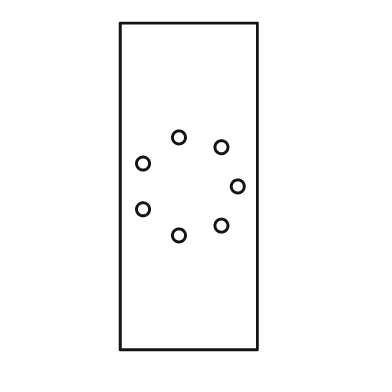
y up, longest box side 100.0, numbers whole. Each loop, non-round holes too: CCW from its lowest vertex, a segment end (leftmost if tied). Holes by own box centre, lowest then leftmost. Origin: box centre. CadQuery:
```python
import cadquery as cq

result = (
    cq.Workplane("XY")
    .moveTo(-21.0, -50.0)
    .lineTo(21.0, -50.0)
    .lineTo(21.0, 50.0)
    .lineTo(-21.0, 50.0)
    .close()
    .moveTo(-3.0, -15.0)
    .circle(2.0)
    .moveTo(10.0, -12.0)
    .circle(2.0)
    .moveTo(-14.0, -7.0)
    .circle(2.0)
    .moveTo(15.0, 0.0)
    .circle(2.0)
    .moveTo(-14.0, 7.0)
    .circle(2.0)
    .moveTo(10.0, 12.0)
    .circle(2.0)
    .moveTo(-3.0, 15.0)
    .circle(2.0)
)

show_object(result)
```